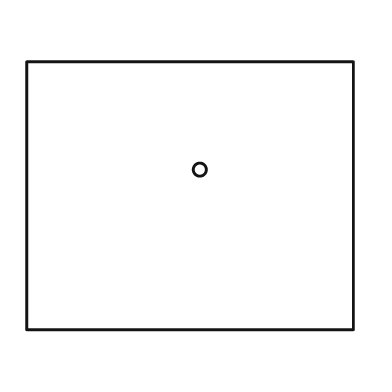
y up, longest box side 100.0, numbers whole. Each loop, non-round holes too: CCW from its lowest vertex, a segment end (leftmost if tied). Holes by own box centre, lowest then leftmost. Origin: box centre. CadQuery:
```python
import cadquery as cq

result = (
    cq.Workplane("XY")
    .moveTo(-50.0, -41.0)
    .lineTo(50.0, -41.0)
    .lineTo(50.0, 41.0)
    .lineTo(-50.0, 41.0)
    .close()
    .moveTo(3.0, 8.0)
    .circle(2.0)
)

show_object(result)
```